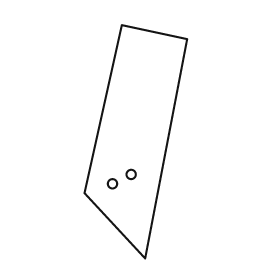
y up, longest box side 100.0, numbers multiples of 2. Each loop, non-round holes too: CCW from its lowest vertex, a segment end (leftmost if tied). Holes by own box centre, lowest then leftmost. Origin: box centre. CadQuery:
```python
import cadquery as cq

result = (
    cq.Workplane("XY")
    .moveTo(4.0, -50.0)
    .lineTo(22.0, 44.0)
    .lineTo(-6.0, 50.0)
    .lineTo(-22.0, -22.0)
    .close()
    .moveTo(-10.0, -18.0)
    .circle(2.0)
    .moveTo(-2.0, -14.0)
    .circle(2.0)
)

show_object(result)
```